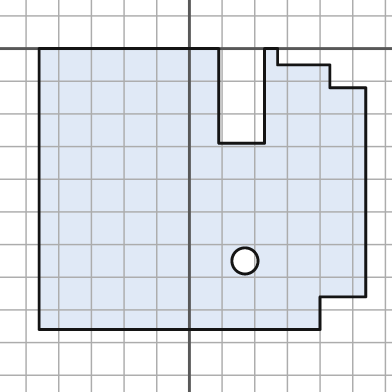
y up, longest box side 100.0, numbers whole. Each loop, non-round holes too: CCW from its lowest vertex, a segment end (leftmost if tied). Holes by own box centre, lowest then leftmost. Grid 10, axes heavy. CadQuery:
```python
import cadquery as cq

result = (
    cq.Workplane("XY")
    .moveTo(-46.0, -86.0)
    .lineTo(40.0, -86.0)
    .lineTo(40.0, -76.0)
    .lineTo(54.0, -76.0)
    .lineTo(54.0, -12.0)
    .lineTo(43.0, -12.0)
    .lineTo(43.0, -5.0)
    .lineTo(27.0, -5.0)
    .lineTo(27.0, 0.0)
    .lineTo(23.0, 0.0)
    .lineTo(23.0, -29.0)
    .lineTo(9.0, -29.0)
    .lineTo(9.0, 0.0)
    .lineTo(-46.0, 0.0)
    .close()
    .moveTo(17.0, -65.0)
    .circle(4.0)
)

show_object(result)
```